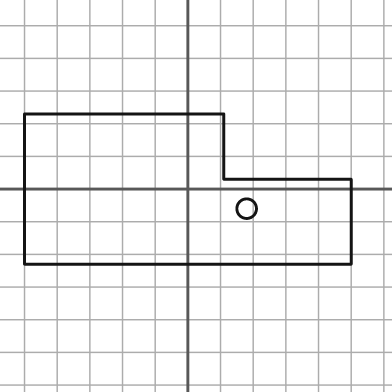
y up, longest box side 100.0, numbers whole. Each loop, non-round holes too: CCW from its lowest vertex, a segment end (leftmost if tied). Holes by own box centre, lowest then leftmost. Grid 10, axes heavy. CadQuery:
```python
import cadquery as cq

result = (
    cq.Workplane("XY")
    .moveTo(-50.0, -23.0)
    .lineTo(50.0, -23.0)
    .lineTo(50.0, 3.0)
    .lineTo(11.0, 3.0)
    .lineTo(11.0, 23.0)
    .lineTo(-50.0, 23.0)
    .close()
    .moveTo(18.0, -6.0)
    .circle(3.0)
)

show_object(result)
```